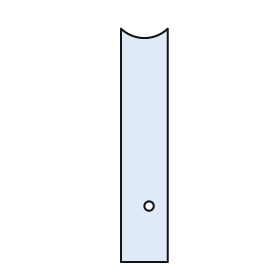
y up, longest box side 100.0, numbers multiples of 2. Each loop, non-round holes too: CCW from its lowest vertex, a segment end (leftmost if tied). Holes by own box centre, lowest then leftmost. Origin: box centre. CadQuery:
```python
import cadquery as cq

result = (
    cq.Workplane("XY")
    .moveTo(-10.0, -50.0)
    .lineTo(10.0, -50.0)
    .lineTo(10.0, 50.0)
    .threePointArc((0.0, 46.0), (-10.0, 50.0))
    .close()
    .moveTo(2.0, -26.0)
    .circle(2.0)
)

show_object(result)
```